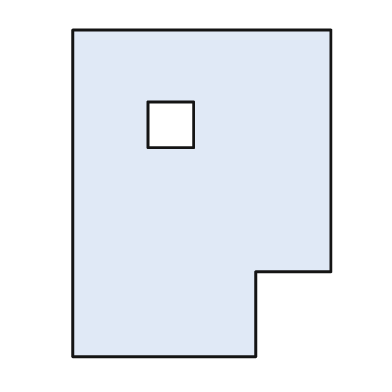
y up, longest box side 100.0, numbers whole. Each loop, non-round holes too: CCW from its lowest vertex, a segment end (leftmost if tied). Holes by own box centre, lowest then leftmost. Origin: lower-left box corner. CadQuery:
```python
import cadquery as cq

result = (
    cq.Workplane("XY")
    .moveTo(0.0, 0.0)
    .lineTo(56.0, 0.0)
    .lineTo(56.0, 26.0)
    .lineTo(79.0, 26.0)
    .lineTo(79.0, 100.0)
    .lineTo(0.0, 100.0)
    .close()
    .moveTo(23.0, 64.0)
    .lineTo(37.0, 64.0)
    .lineTo(37.0, 78.0)
    .lineTo(23.0, 78.0)
    .close()
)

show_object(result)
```